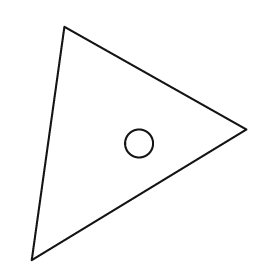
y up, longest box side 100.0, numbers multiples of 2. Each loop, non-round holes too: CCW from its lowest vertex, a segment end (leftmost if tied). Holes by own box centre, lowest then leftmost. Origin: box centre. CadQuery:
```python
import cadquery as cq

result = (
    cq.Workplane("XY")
    .moveTo(-46.0, -50.0)
    .lineTo(46.0, 6.0)
    .lineTo(-32.0, 50.0)
    .close()
    .moveTo(0.0, 0.0)
    .circle(6.0)
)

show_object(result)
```